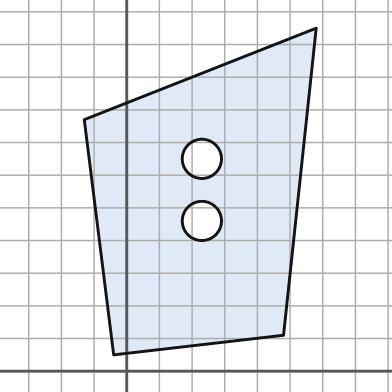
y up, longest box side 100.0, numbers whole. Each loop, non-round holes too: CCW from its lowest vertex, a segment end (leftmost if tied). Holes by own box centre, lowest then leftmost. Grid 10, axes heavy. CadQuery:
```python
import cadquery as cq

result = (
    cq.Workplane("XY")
    .moveTo(-4.0, 5.0)
    .lineTo(48.0, 11.0)
    .lineTo(58.0, 105.0)
    .lineTo(-13.0, 77.0)
    .close()
    .moveTo(23.0, 46.0)
    .circle(6.0)
    .moveTo(23.0, 65.0)
    .circle(6.0)
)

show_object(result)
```